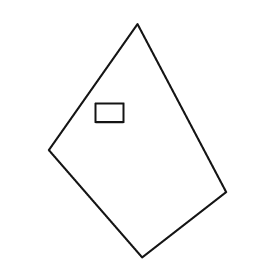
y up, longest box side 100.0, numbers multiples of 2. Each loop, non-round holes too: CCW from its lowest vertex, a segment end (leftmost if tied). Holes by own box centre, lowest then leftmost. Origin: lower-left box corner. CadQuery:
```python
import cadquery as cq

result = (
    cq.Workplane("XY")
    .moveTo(40.0, 0.0)
    .lineTo(76.0, 28.0)
    .lineTo(38.0, 100.0)
    .lineTo(0.0, 46.0)
    .close()
    .moveTo(20.0, 58.0)
    .lineTo(32.0, 58.0)
    .lineTo(32.0, 66.0)
    .lineTo(20.0, 66.0)
    .close()
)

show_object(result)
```